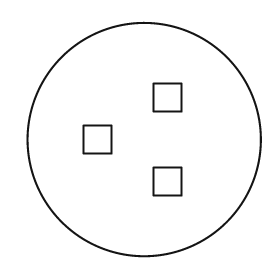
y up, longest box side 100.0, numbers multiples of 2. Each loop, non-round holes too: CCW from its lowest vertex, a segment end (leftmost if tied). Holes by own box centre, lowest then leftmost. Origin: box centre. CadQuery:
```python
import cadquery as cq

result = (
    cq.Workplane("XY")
    .moveTo(0.0, 0.0)
    .circle(50.0)
    .moveTo(4.0, -24.0)
    .lineTo(16.0, -24.0)
    .lineTo(16.0, -12.0)
    .lineTo(4.0, -12.0)
    .close()
    .moveTo(-26.0, -6.0)
    .lineTo(-14.0, -6.0)
    .lineTo(-14.0, 6.0)
    .lineTo(-26.0, 6.0)
    .close()
    .moveTo(4.0, 12.0)
    .lineTo(16.0, 12.0)
    .lineTo(16.0, 24.0)
    .lineTo(4.0, 24.0)
    .close()
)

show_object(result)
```